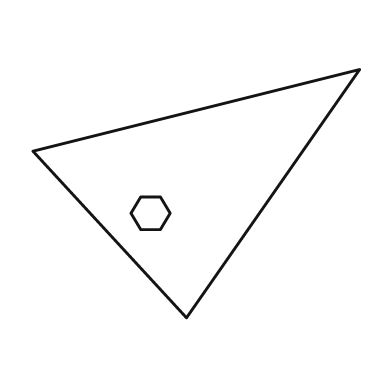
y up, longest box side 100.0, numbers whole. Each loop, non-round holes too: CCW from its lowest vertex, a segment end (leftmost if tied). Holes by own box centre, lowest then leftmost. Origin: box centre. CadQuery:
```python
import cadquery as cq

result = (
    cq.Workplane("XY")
    .moveTo(-3.0, -38.0)
    .lineTo(50.0, 38.0)
    .lineTo(-50.0, 13.0)
    .close()
    .moveTo(-17.0, -11.0)
    .lineTo(-11.0, -11.0)
    .lineTo(-8.0, -6.0)
    .lineTo(-11.0, -1.0)
    .lineTo(-17.0, -1.0)
    .lineTo(-20.0, -6.0)
    .close()
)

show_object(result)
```